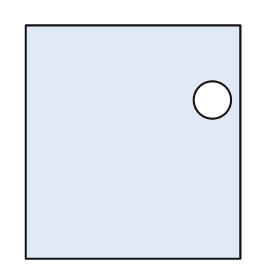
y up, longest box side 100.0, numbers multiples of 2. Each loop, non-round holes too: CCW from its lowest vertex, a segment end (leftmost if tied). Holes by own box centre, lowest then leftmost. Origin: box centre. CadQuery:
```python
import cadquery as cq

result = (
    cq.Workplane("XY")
    .moveTo(-46.0, -50.0)
    .lineTo(46.0, -50.0)
    .lineTo(46.0, 50.0)
    .lineTo(-46.0, 50.0)
    .close()
    .moveTo(34.0, 18.0)
    .circle(8.0)
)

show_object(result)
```